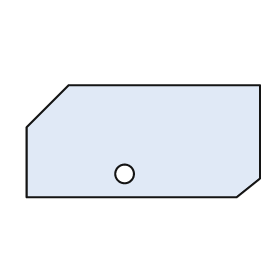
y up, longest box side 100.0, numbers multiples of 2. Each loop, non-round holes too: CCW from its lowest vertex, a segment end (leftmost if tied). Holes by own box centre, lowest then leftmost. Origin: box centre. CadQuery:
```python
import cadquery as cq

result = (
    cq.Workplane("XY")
    .moveTo(-50.0, -24.0)
    .lineTo(40.0, -24.0)
    .lineTo(50.0, -16.0)
    .lineTo(50.0, 24.0)
    .lineTo(-32.0, 24.0)
    .lineTo(-50.0, 6.0)
    .close()
    .moveTo(-8.0, -14.0)
    .circle(4.0)
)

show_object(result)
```